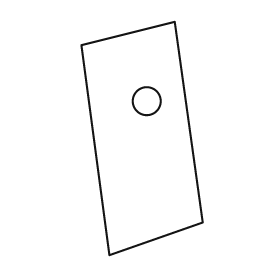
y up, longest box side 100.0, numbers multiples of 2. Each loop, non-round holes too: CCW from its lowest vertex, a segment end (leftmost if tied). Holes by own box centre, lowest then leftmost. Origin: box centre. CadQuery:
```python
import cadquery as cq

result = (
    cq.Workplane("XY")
    .moveTo(-14.0, -50.0)
    .lineTo(26.0, -36.0)
    .lineTo(14.0, 50.0)
    .lineTo(-26.0, 40.0)
    .close()
    .moveTo(2.0, 16.0)
    .circle(6.0)
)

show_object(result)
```